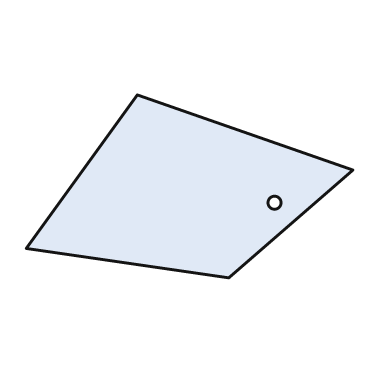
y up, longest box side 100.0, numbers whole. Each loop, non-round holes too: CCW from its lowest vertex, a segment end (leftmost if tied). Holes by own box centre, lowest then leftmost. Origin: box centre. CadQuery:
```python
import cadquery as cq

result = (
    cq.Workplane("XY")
    .moveTo(12.0, -28.0)
    .lineTo(50.0, 5.0)
    .lineTo(-16.0, 28.0)
    .lineTo(-50.0, -19.0)
    .close()
    .moveTo(26.0, -5.0)
    .circle(2.0)
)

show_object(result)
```